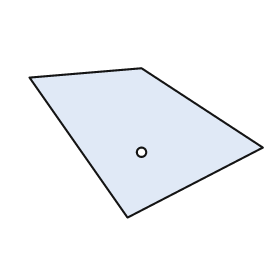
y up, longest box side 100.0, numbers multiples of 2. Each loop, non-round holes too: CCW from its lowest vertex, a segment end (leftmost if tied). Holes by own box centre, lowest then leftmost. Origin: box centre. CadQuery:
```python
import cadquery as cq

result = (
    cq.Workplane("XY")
    .moveTo(-8.0, -32.0)
    .lineTo(50.0, -2.0)
    .lineTo(-2.0, 32.0)
    .lineTo(-50.0, 28.0)
    .close()
    .moveTo(-2.0, -4.0)
    .circle(2.0)
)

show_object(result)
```